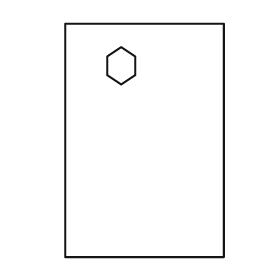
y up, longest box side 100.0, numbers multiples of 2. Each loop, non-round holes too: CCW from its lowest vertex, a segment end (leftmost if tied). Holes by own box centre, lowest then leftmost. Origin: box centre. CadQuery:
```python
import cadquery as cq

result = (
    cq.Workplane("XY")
    .moveTo(-34.0, -50.0)
    .lineTo(34.0, -50.0)
    .lineTo(34.0, 50.0)
    .lineTo(-34.0, 50.0)
    .close()
    .moveTo(-10.0, 24.0)
    .lineTo(-4.0, 28.0)
    .lineTo(-4.0, 36.0)
    .lineTo(-10.0, 40.0)
    .lineTo(-16.0, 36.0)
    .lineTo(-16.0, 28.0)
    .close()
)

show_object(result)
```